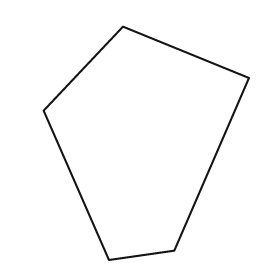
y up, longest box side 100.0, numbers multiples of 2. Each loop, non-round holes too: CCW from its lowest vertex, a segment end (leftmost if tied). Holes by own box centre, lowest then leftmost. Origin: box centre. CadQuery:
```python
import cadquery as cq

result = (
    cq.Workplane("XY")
    .moveTo(-16.0, -50.0)
    .lineTo(12.0, -46.0)
    .lineTo(44.0, 28.0)
    .lineTo(-10.0, 50.0)
    .lineTo(-44.0, 14.0)
    .close()
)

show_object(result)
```